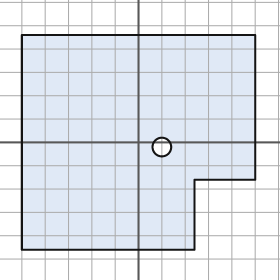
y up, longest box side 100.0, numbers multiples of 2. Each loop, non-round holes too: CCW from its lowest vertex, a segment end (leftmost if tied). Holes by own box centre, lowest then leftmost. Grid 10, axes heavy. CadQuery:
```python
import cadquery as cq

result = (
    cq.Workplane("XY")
    .moveTo(-50.0, -46.0)
    .lineTo(24.0, -46.0)
    .lineTo(24.0, -16.0)
    .lineTo(50.0, -16.0)
    .lineTo(50.0, 46.0)
    .lineTo(-50.0, 46.0)
    .close()
    .moveTo(10.0, -2.0)
    .circle(4.0)
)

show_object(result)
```